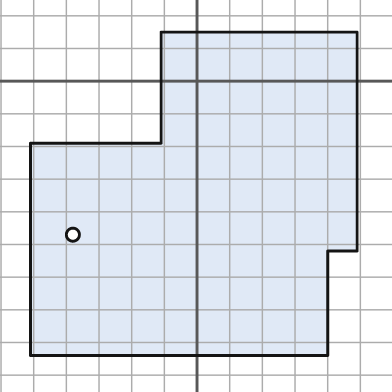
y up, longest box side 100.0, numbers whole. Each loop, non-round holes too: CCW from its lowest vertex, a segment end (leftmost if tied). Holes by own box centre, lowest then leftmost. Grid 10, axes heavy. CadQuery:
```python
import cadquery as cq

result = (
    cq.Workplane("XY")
    .moveTo(-51.0, -84.0)
    .lineTo(40.0, -84.0)
    .lineTo(40.0, -52.0)
    .lineTo(49.0, -52.0)
    .lineTo(49.0, 15.0)
    .lineTo(-11.0, 15.0)
    .lineTo(-11.0, -19.0)
    .lineTo(-51.0, -19.0)
    .close()
    .moveTo(-38.0, -47.0)
    .circle(2.0)
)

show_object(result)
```